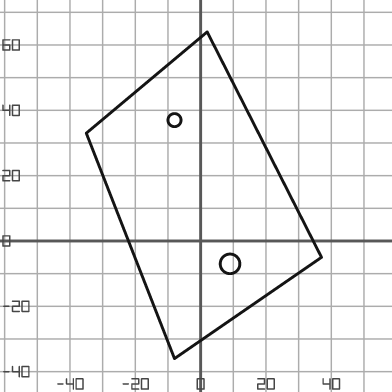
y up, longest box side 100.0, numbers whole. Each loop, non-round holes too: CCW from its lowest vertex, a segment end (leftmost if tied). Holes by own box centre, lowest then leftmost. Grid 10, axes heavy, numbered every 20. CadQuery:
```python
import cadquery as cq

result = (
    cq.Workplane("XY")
    .moveTo(-8.0, -36.0)
    .lineTo(37.0, -5.0)
    .lineTo(2.0, 64.0)
    .lineTo(-35.0, 33.0)
    .close()
    .moveTo(9.0, -7.0)
    .circle(3.0)
    .moveTo(-8.0, 37.0)
    .circle(2.0)
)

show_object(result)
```